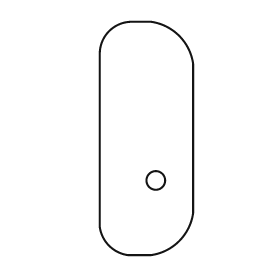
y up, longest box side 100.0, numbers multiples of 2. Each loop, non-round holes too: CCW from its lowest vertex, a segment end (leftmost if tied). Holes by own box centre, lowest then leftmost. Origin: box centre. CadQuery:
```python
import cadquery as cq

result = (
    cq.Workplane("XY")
    .moveTo(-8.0, -50.0)
    .lineTo(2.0, -50.0)
    .threePointArc((14.0, -44.0), (20.0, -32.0))
    .lineTo(20.0, 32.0)
    .threePointArc((14.0, 44.0), (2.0, 50.0))
    .lineTo(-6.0, 50.0)
    .threePointArc((-16.0, 46.0), (-20.0, 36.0))
    .lineTo(-20.0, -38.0)
    .threePointArc((-16.0, -46.0), (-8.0, -50.0))
    .close()
    .moveTo(4.0, -18.0)
    .circle(4.0)
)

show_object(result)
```